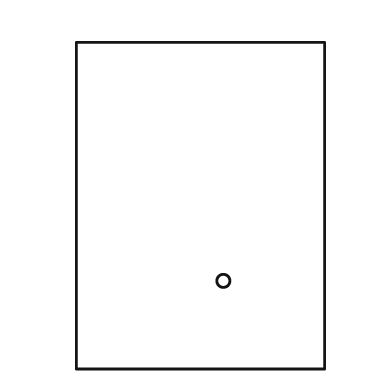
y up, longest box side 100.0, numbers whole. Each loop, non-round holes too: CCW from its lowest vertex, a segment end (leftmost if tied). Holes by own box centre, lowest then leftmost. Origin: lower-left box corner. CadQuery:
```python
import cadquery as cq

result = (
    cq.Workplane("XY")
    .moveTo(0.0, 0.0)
    .lineTo(76.0, 0.0)
    .lineTo(76.0, 100.0)
    .lineTo(0.0, 100.0)
    .close()
    .moveTo(45.0, 27.0)
    .circle(2.0)
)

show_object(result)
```